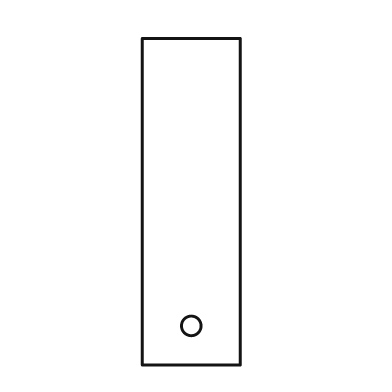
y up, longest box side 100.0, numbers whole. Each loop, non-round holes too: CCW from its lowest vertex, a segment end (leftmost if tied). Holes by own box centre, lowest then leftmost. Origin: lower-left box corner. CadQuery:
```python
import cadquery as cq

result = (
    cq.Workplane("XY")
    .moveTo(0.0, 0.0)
    .lineTo(30.0, 0.0)
    .lineTo(30.0, 100.0)
    .lineTo(0.0, 100.0)
    .close()
    .moveTo(15.0, 12.0)
    .circle(3.0)
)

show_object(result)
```